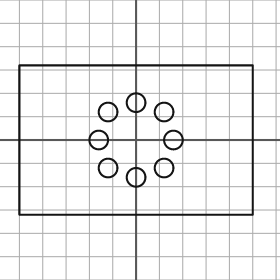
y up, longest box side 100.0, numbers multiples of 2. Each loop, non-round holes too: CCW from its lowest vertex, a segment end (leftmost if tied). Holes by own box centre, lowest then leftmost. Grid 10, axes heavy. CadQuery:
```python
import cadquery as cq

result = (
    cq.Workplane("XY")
    .moveTo(-50.0, -32.0)
    .lineTo(50.0, -32.0)
    .lineTo(50.0, 32.0)
    .lineTo(-50.0, 32.0)
    .close()
    .moveTo(0.0, -16.0)
    .circle(4.0)
    .moveTo(-12.0, -12.0)
    .circle(4.0)
    .moveTo(12.0, -12.0)
    .circle(4.0)
    .moveTo(-16.0, 0.0)
    .circle(4.0)
    .moveTo(16.0, 0.0)
    .circle(4.0)
    .moveTo(-12.0, 12.0)
    .circle(4.0)
    .moveTo(12.0, 12.0)
    .circle(4.0)
    .moveTo(0.0, 16.0)
    .circle(4.0)
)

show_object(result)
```